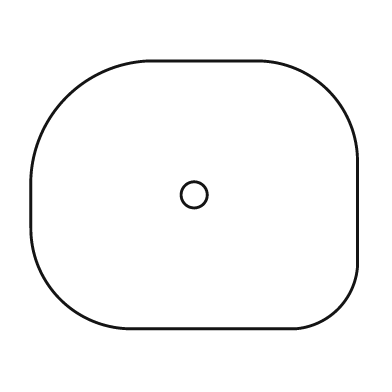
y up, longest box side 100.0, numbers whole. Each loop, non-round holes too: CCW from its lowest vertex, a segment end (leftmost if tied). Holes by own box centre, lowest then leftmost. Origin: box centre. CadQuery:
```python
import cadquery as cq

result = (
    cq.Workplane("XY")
    .moveTo(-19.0, -41.0)
    .lineTo(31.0, -41.0)
    .threePointArc((44.0, -35.0), (50.0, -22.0))
    .lineTo(50.0, 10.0)
    .threePointArc((41.0, 32.0), (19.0, 41.0))
    .lineTo(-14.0, 41.0)
    .threePointArc((-39.0, 30.0), (-50.0, 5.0))
    .lineTo(-50.0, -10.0)
    .threePointArc((-41.0, -32.0), (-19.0, -41.0))
    .close()
    .moveTo(0.0, 0.0)
    .circle(4.0)
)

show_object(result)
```